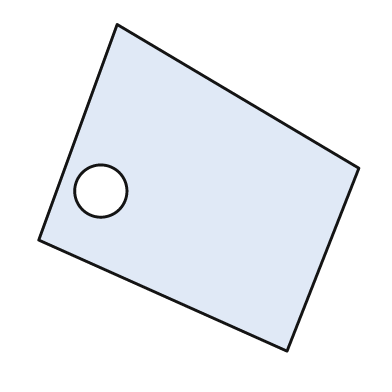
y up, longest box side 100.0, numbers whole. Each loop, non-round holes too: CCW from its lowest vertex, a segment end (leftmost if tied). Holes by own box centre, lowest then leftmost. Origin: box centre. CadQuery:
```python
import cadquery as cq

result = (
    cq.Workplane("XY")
    .moveTo(27.0, -50.0)
    .lineTo(49.0, 6.0)
    .lineTo(-25.0, 50.0)
    .lineTo(-49.0, -16.0)
    .close()
    .moveTo(-30.0, -1.0)
    .circle(8.0)
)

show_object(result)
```